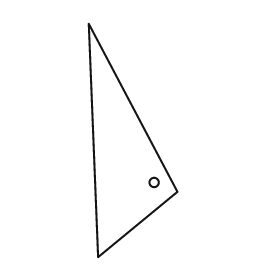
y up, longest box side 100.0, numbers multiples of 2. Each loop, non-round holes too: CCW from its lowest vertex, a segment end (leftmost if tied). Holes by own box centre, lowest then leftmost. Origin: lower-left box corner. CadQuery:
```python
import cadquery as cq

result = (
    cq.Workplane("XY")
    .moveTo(4.0, 0.0)
    .lineTo(38.0, 28.0)
    .lineTo(0.0, 100.0)
    .close()
    .moveTo(28.0, 32.0)
    .circle(2.0)
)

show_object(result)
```